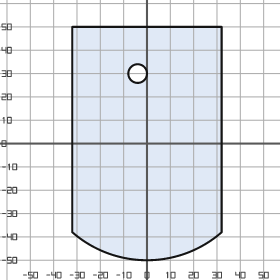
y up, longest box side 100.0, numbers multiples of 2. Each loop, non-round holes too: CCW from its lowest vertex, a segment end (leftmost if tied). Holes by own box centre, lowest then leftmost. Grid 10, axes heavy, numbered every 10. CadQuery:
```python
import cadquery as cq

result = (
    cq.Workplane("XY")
    .moveTo(-32.0, -38.0)
    .threePointArc((0.0, -50.0), (32.0, -38.0))
    .lineTo(32.0, 50.0)
    .lineTo(-32.0, 50.0)
    .close()
    .moveTo(-4.0, 30.0)
    .circle(4.0)
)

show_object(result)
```